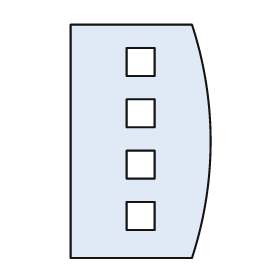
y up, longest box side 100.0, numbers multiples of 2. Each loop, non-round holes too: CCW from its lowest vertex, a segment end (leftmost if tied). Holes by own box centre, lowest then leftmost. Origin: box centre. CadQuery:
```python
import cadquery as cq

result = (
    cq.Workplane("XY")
    .moveTo(-30.0, -50.0)
    .lineTo(22.0, -50.0)
    .threePointArc((30.0, 0.0), (22.0, 50.0))
    .lineTo(-30.0, 50.0)
    .close()
    .moveTo(-6.0, -38.0)
    .lineTo(6.0, -38.0)
    .lineTo(6.0, -26.0)
    .lineTo(-6.0, -26.0)
    .close()
    .moveTo(-6.0, -16.0)
    .lineTo(6.0, -16.0)
    .lineTo(6.0, -4.0)
    .lineTo(-6.0, -4.0)
    .close()
    .moveTo(-6.0, 6.0)
    .lineTo(6.0, 6.0)
    .lineTo(6.0, 18.0)
    .lineTo(-6.0, 18.0)
    .close()
    .moveTo(-6.0, 28.0)
    .lineTo(6.0, 28.0)
    .lineTo(6.0, 40.0)
    .lineTo(-6.0, 40.0)
    .close()
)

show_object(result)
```